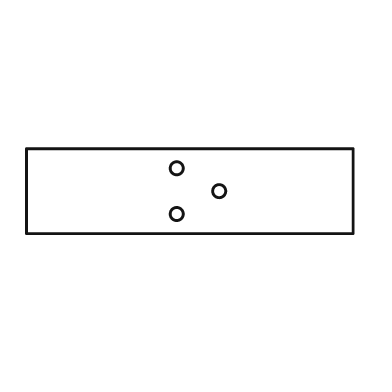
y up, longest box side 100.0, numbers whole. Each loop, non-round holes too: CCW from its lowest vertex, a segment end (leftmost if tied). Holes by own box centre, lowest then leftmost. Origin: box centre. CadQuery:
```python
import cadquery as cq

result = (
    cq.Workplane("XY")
    .moveTo(-50.0, -13.0)
    .lineTo(50.0, -13.0)
    .lineTo(50.0, 13.0)
    .lineTo(-50.0, 13.0)
    .close()
    .moveTo(-4.0, -7.0)
    .circle(2.0)
    .moveTo(9.0, 0.0)
    .circle(2.0)
    .moveTo(-4.0, 7.0)
    .circle(2.0)
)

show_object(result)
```